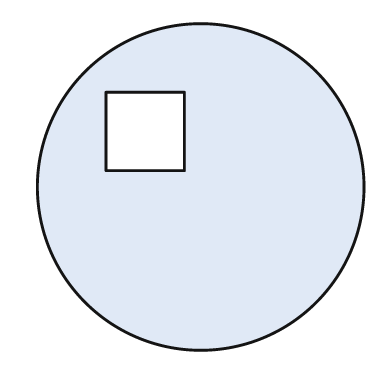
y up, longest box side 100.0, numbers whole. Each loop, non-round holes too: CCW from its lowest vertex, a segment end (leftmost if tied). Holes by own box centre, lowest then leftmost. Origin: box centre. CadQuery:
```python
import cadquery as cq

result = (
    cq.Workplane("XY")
    .moveTo(0.0, 0.0)
    .circle(50.0)
    .moveTo(-29.0, 5.0)
    .lineTo(-5.0, 5.0)
    .lineTo(-5.0, 29.0)
    .lineTo(-29.0, 29.0)
    .close()
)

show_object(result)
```